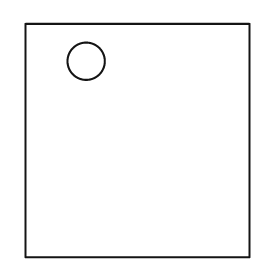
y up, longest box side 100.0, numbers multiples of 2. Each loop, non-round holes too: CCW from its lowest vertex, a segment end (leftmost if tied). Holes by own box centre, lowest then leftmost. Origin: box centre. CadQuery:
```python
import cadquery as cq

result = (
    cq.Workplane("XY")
    .moveTo(-48.0, -50.0)
    .lineTo(48.0, -50.0)
    .lineTo(48.0, 50.0)
    .lineTo(-48.0, 50.0)
    .close()
    .moveTo(-22.0, 34.0)
    .circle(8.0)
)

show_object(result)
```